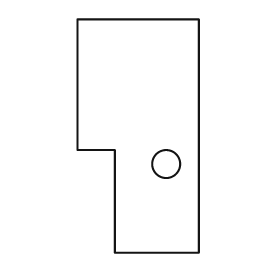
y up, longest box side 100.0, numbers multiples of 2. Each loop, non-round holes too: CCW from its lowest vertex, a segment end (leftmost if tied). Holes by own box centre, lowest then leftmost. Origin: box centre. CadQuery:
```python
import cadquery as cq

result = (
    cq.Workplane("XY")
    .moveTo(-10.0, -50.0)
    .lineTo(26.0, -50.0)
    .lineTo(26.0, 50.0)
    .lineTo(-26.0, 50.0)
    .lineTo(-26.0, -6.0)
    .lineTo(-10.0, -6.0)
    .close()
    .moveTo(12.0, -12.0)
    .circle(6.0)
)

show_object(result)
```